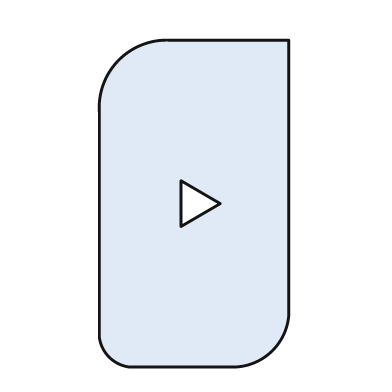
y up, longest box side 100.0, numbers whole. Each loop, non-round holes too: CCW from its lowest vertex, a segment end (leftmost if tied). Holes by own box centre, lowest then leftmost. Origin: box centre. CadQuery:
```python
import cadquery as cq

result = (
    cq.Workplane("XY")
    .moveTo(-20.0, -50.0)
    .lineTo(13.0, -50.0)
    .threePointArc((24.0, -45.0), (29.0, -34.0))
    .lineTo(29.0, 50.0)
    .lineTo(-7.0, 50.0)
    .threePointArc((-23.0, 44.0), (-29.0, 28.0))
    .lineTo(-29.0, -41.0)
    .threePointArc((-26.0, -47.0), (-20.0, -50.0))
    .close()
    .moveTo(-4.0, -7.0)
    .lineTo(8.0, 0.0)
    .lineTo(-4.0, 7.0)
    .close()
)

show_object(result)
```